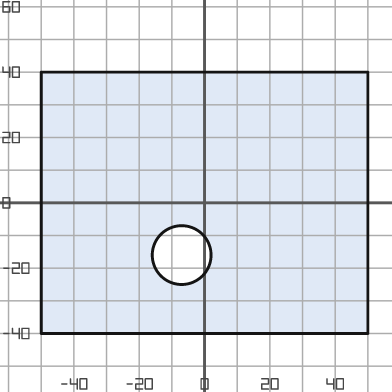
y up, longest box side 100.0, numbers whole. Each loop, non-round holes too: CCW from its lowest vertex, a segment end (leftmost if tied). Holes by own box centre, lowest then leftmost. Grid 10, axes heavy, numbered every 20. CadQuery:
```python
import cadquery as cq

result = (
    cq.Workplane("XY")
    .moveTo(-50.0, -40.0)
    .lineTo(50.0, -40.0)
    .lineTo(50.0, 40.0)
    .lineTo(-50.0, 40.0)
    .close()
    .moveTo(-7.0, -16.0)
    .circle(9.0)
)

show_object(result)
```